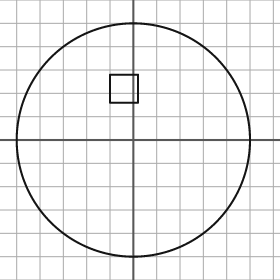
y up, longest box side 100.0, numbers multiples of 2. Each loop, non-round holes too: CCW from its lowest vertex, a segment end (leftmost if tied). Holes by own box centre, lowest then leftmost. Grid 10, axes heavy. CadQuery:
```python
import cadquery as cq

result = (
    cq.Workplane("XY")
    .moveTo(0.0, 0.0)
    .circle(50.0)
    .moveTo(-10.0, 16.0)
    .lineTo(2.0, 16.0)
    .lineTo(2.0, 28.0)
    .lineTo(-10.0, 28.0)
    .close()
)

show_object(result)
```